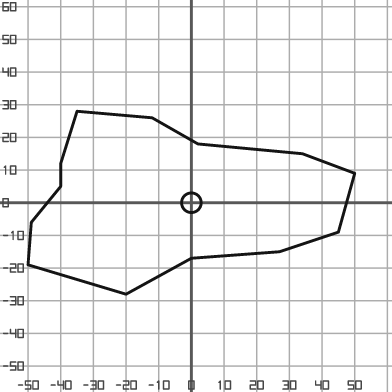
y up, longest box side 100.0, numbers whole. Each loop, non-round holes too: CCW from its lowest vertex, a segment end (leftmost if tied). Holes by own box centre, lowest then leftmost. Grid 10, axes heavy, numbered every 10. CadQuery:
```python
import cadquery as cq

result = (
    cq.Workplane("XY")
    .moveTo(-20.0, -28.0)
    .lineTo(0.0, -17.0)
    .lineTo(27.0, -15.0)
    .lineTo(45.0, -9.0)
    .lineTo(50.0, 9.0)
    .lineTo(34.0, 15.0)
    .lineTo(2.0, 18.0)
    .lineTo(-12.0, 26.0)
    .lineTo(-35.0, 28.0)
    .lineTo(-40.0, 12.0)
    .lineTo(-40.0, 5.0)
    .lineTo(-49.0, -6.0)
    .lineTo(-50.0, -19.0)
    .close()
    .moveTo(0.0, 0.0)
    .circle(3.0)
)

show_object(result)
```